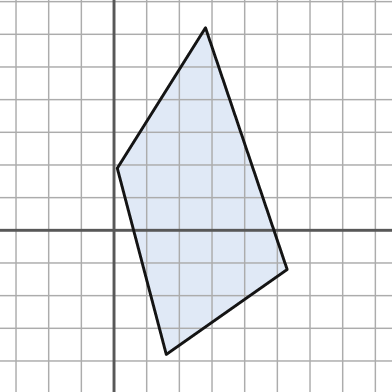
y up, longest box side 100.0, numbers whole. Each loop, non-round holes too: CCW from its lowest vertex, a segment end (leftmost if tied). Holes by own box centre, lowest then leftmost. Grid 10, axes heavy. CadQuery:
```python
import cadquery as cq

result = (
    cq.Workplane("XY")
    .moveTo(16.0, -38.0)
    .lineTo(53.0, -12.0)
    .lineTo(28.0, 62.0)
    .lineTo(1.0, 19.0)
    .close()
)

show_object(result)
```